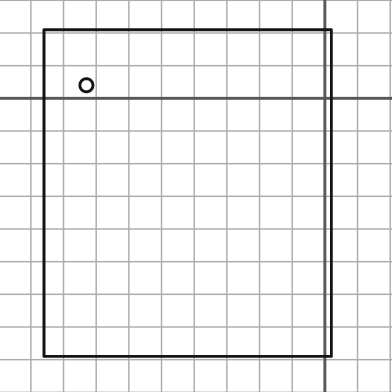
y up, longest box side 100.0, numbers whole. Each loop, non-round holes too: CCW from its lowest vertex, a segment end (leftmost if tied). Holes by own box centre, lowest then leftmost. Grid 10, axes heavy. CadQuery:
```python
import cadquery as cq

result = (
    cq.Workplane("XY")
    .moveTo(-86.0, -79.0)
    .lineTo(2.0, -79.0)
    .lineTo(2.0, 21.0)
    .lineTo(-86.0, 21.0)
    .close()
    .moveTo(-73.0, 4.0)
    .circle(2.0)
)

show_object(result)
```